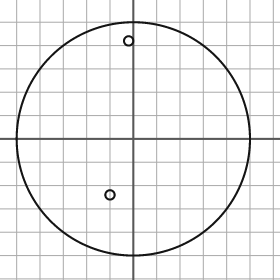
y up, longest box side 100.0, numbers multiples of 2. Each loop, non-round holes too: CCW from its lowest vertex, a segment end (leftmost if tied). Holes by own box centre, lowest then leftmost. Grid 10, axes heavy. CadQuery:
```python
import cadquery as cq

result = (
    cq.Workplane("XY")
    .moveTo(0.0, 0.0)
    .circle(50.0)
    .moveTo(-10.0, -24.0)
    .circle(2.0)
    .moveTo(-2.0, 42.0)
    .circle(2.0)
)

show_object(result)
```